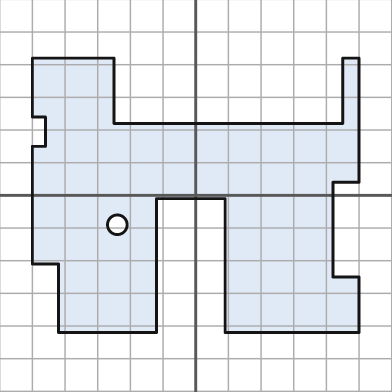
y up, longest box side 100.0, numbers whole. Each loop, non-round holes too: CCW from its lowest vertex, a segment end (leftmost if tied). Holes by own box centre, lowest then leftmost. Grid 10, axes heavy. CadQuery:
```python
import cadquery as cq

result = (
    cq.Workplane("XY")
    .moveTo(-42.0, -42.0)
    .lineTo(-12.0, -42.0)
    .lineTo(-12.0, -1.0)
    .lineTo(9.0, -1.0)
    .lineTo(9.0, -42.0)
    .lineTo(50.0, -42.0)
    .lineTo(50.0, -25.0)
    .lineTo(42.0, -25.0)
    .lineTo(42.0, 4.0)
    .lineTo(50.0, 4.0)
    .lineTo(50.0, 42.0)
    .lineTo(45.0, 42.0)
    .lineTo(45.0, 22.0)
    .lineTo(-25.0, 22.0)
    .lineTo(-25.0, 42.0)
    .lineTo(-50.0, 42.0)
    .lineTo(-50.0, 24.0)
    .lineTo(-46.0, 24.0)
    .lineTo(-46.0, 15.0)
    .lineTo(-50.0, 15.0)
    .lineTo(-50.0, -21.0)
    .lineTo(-42.0, -21.0)
    .close()
    .moveTo(-24.0, -9.0)
    .circle(3.0)
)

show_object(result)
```